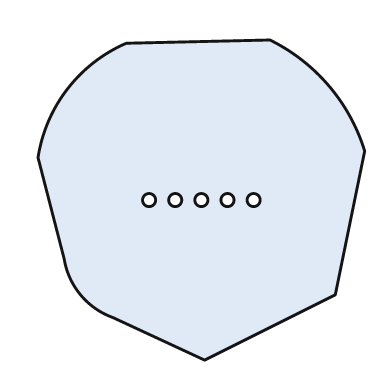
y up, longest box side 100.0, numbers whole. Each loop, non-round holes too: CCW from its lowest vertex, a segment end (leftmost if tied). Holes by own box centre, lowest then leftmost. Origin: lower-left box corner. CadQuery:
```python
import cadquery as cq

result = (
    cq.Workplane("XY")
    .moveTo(51.0, 0.0)
    .lineTo(91.0, 20.0)
    .lineTo(100.0, 64.0)
    .threePointArc((89.0, 84.0), (71.0, 98.0))
    .lineTo(27.0, 97.0)
    .threePointArc((9.0, 83.0), (0.0, 62.0))
    .lineTo(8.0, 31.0)
    .threePointArc((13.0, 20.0), (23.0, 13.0))
    .close()
    .moveTo(34.0, 49.0)
    .circle(2.0)
    .moveTo(42.0, 49.0)
    .circle(2.0)
    .moveTo(50.0, 49.0)
    .circle(2.0)
    .moveTo(58.0, 49.0)
    .circle(2.0)
    .moveTo(66.0, 49.0)
    .circle(2.0)
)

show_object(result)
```